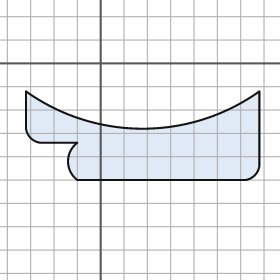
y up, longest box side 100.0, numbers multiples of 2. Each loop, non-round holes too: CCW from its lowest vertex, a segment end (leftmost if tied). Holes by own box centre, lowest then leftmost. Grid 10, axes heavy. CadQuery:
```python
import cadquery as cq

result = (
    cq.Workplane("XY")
    .moveTo(-10.0, -50.0)
    .lineTo(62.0, -50.0)
    .threePointArc((66.0, -48.0), (68.0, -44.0))
    .lineTo(68.0, -12.0)
    .threePointArc((18.0, -28.0), (-32.0, -12.0))
    .lineTo(-32.0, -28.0)
    .threePointArc((-30.0, -32.0), (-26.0, -34.0))
    .lineTo(-10.0, -34.0)
    .threePointArc((-14.0, -42.0), (-10.0, -50.0))
    .close()
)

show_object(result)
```